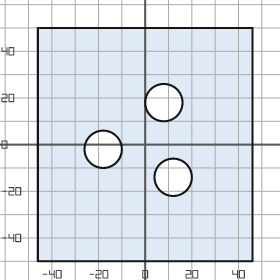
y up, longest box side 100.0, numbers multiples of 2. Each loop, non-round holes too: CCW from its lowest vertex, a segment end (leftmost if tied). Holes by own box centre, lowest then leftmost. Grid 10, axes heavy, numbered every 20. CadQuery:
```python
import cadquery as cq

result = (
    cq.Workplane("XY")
    .moveTo(-46.0, -50.0)
    .lineTo(46.0, -50.0)
    .lineTo(46.0, 50.0)
    .lineTo(-46.0, 50.0)
    .close()
    .moveTo(12.0, -14.0)
    .circle(8.0)
    .moveTo(-18.0, -2.0)
    .circle(8.0)
    .moveTo(8.0, 18.0)
    .circle(8.0)
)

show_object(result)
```